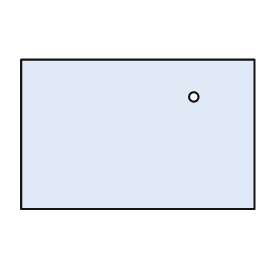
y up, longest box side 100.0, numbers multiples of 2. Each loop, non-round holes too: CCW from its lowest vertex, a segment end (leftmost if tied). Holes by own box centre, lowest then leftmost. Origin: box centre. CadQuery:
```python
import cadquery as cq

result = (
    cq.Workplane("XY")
    .moveTo(-50.0, -32.0)
    .lineTo(50.0, -32.0)
    .lineTo(50.0, 32.0)
    .lineTo(-50.0, 32.0)
    .close()
    .moveTo(24.0, 16.0)
    .circle(2.0)
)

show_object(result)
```